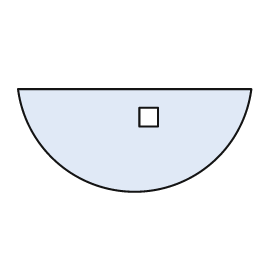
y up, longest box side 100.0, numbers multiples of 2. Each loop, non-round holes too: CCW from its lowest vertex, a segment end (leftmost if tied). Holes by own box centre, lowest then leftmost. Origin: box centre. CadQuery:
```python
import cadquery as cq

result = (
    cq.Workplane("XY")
    .moveTo(-50.0, 22.0)
    .threePointArc((0.0, -22.0), (50.0, 22.0))
    .close()
    .moveTo(2.0, 6.0)
    .lineTo(10.0, 6.0)
    .lineTo(10.0, 14.0)
    .lineTo(2.0, 14.0)
    .close()
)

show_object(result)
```